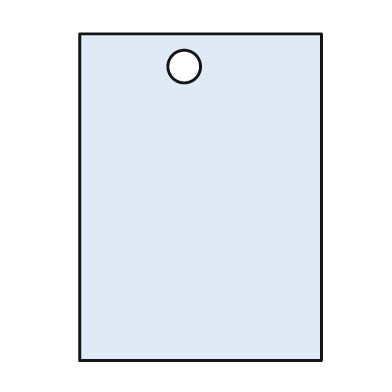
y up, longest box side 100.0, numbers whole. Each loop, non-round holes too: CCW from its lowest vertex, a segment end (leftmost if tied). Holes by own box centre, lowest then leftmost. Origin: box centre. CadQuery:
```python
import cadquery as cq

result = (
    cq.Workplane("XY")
    .moveTo(-37.0, -50.0)
    .lineTo(37.0, -50.0)
    .lineTo(37.0, 50.0)
    .lineTo(-37.0, 50.0)
    .close()
    .moveTo(-5.0, 40.0)
    .circle(5.0)
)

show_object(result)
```